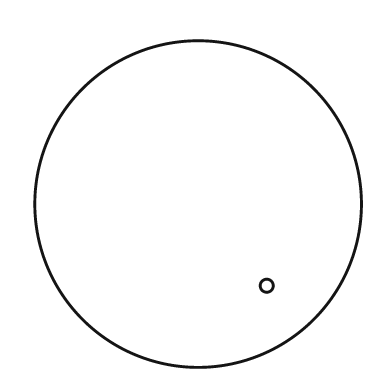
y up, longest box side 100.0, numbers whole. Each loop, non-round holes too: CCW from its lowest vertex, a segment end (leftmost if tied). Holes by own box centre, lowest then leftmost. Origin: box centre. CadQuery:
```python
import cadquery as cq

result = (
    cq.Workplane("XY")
    .moveTo(0.0, 0.0)
    .circle(50.0)
    .moveTo(21.0, -25.0)
    .circle(2.0)
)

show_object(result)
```